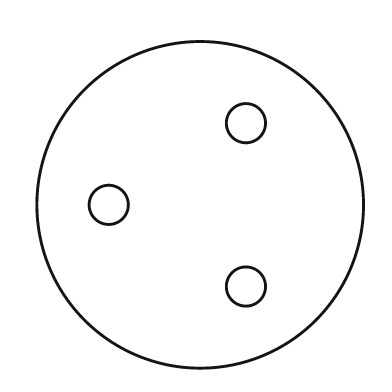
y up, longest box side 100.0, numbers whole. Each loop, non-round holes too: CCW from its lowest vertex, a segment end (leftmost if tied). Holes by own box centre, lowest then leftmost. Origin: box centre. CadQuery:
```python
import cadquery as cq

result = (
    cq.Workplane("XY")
    .moveTo(0.0, 0.0)
    .circle(50.0)
    .moveTo(14.0, -25.0)
    .circle(6.0)
    .moveTo(-28.0, 0.0)
    .circle(6.0)
    .moveTo(14.0, 25.0)
    .circle(6.0)
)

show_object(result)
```